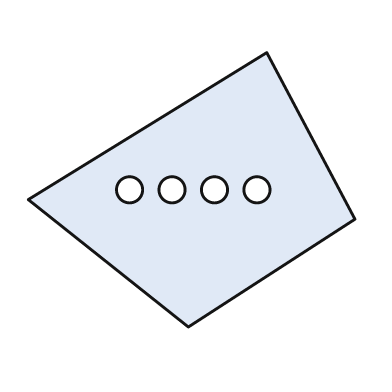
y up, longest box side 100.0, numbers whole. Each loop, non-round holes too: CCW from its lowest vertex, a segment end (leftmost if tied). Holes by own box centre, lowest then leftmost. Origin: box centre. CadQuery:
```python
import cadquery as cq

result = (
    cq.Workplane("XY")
    .moveTo(-1.0, -42.0)
    .lineTo(50.0, -9.0)
    .lineTo(23.0, 42.0)
    .lineTo(-50.0, -3.0)
    .close()
    .moveTo(-19.0, 0.0)
    .circle(4.0)
    .moveTo(-6.0, 0.0)
    .circle(4.0)
    .moveTo(7.0, 0.0)
    .circle(4.0)
    .moveTo(20.0, 0.0)
    .circle(4.0)
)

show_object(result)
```